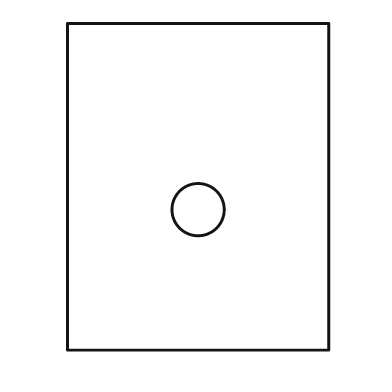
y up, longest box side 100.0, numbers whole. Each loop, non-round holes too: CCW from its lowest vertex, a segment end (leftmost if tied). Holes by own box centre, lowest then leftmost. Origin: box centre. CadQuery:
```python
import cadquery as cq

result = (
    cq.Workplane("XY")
    .moveTo(-40.0, -50.0)
    .lineTo(40.0, -50.0)
    .lineTo(40.0, 50.0)
    .lineTo(-40.0, 50.0)
    .close()
    .moveTo(0.0, -7.0)
    .circle(8.0)
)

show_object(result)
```